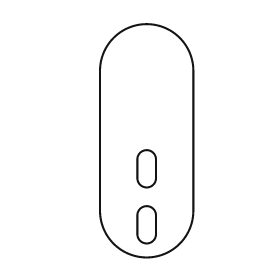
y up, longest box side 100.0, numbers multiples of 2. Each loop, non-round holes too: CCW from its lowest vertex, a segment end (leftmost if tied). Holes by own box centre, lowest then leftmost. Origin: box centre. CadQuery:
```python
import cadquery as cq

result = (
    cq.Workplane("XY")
    .moveTo(-20.0, -30.0)
    .threePointArc((0.0, -50.0), (20.0, -30.0))
    .lineTo(20.0, 30.0)
    .threePointArc((0.0, 50.0), (-20.0, 30.0))
    .close()
    .moveTo(-4.0, -40.0)
    .threePointArc((0.0, -44.0), (4.0, -40.0))
    .lineTo(4.0, -32.0)
    .threePointArc((0.0, -28.0), (-4.0, -32.0))
    .close()
    .moveTo(-4.0, -16.0)
    .threePointArc((0.0, -20.0), (4.0, -16.0))
    .lineTo(4.0, -8.0)
    .threePointArc((0.0, -4.0), (-4.0, -8.0))
    .close()
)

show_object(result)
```